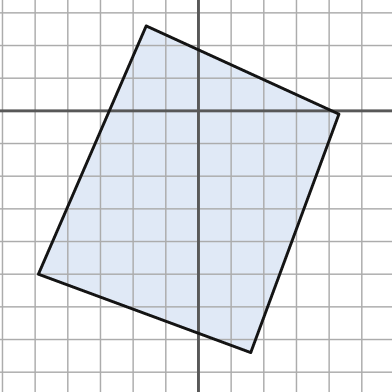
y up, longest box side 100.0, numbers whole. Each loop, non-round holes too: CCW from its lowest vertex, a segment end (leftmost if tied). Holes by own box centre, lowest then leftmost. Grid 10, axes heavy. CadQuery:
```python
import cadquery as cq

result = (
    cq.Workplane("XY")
    .moveTo(16.0, -74.0)
    .lineTo(43.0, -1.0)
    .lineTo(-16.0, 26.0)
    .lineTo(-49.0, -50.0)
    .close()
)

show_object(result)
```